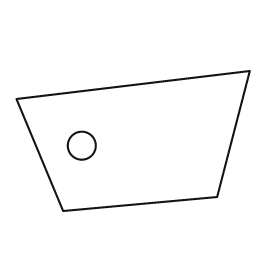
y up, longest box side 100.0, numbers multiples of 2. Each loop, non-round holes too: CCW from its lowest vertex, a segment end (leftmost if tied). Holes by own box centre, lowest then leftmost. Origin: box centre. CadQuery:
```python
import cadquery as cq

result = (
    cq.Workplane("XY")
    .moveTo(-30.0, -30.0)
    .lineTo(36.0, -24.0)
    .lineTo(50.0, 30.0)
    .lineTo(-50.0, 18.0)
    .close()
    .moveTo(-22.0, -2.0)
    .circle(6.0)
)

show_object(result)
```